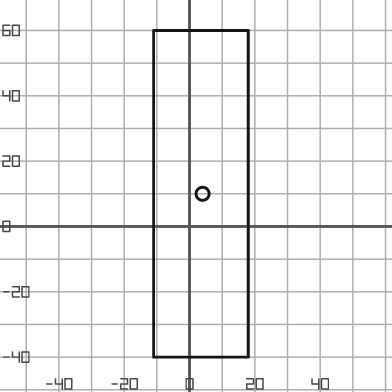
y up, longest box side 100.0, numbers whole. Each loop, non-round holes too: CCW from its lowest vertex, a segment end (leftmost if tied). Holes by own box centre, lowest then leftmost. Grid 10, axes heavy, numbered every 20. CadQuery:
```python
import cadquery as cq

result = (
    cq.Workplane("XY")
    .moveTo(-11.0, -40.0)
    .lineTo(18.0, -40.0)
    .lineTo(18.0, 60.0)
    .lineTo(-11.0, 60.0)
    .close()
    .moveTo(4.0, 10.0)
    .circle(2.0)
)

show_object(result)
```